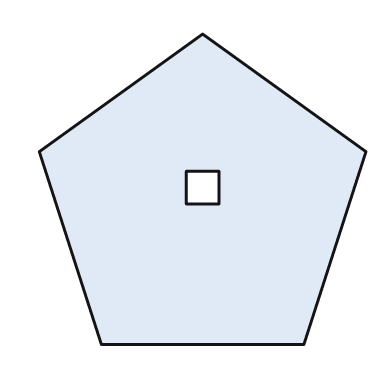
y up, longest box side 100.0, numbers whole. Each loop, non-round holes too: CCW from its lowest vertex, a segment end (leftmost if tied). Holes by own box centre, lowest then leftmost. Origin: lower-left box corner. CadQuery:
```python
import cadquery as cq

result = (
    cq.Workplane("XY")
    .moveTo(19.0, 0.0)
    .lineTo(81.0, 0.0)
    .lineTo(100.0, 59.0)
    .lineTo(50.0, 95.0)
    .lineTo(0.0, 59.0)
    .close()
    .moveTo(45.0, 43.0)
    .lineTo(55.0, 43.0)
    .lineTo(55.0, 53.0)
    .lineTo(45.0, 53.0)
    .close()
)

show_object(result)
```